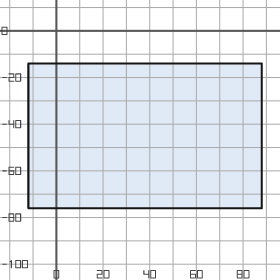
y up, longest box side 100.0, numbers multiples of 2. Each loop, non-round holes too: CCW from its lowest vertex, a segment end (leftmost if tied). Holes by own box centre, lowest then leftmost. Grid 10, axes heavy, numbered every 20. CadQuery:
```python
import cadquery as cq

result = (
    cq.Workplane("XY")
    .moveTo(-12.0, -76.0)
    .lineTo(88.0, -76.0)
    .lineTo(88.0, -14.0)
    .lineTo(-12.0, -14.0)
    .close()
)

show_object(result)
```